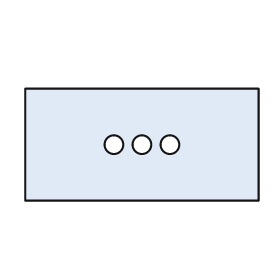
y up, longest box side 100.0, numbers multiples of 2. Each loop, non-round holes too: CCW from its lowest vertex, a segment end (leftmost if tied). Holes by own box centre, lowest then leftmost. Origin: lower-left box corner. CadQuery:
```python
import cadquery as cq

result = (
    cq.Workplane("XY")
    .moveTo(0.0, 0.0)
    .lineTo(100.0, 0.0)
    .lineTo(100.0, 48.0)
    .lineTo(0.0, 48.0)
    .close()
    .moveTo(38.0, 24.0)
    .circle(4.0)
    .moveTo(50.0, 24.0)
    .circle(4.0)
    .moveTo(62.0, 24.0)
    .circle(4.0)
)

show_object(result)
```